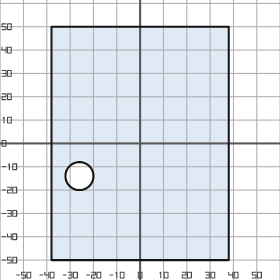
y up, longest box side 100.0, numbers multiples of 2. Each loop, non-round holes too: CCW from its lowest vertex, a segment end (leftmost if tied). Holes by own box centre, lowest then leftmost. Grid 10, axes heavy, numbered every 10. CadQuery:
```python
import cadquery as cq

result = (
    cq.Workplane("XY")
    .moveTo(-38.0, -50.0)
    .lineTo(38.0, -50.0)
    .lineTo(38.0, 50.0)
    .lineTo(-38.0, 50.0)
    .close()
    .moveTo(-26.0, -14.0)
    .circle(6.0)
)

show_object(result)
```